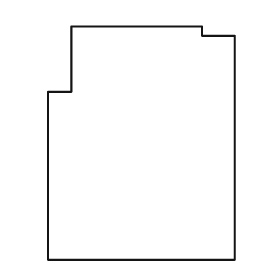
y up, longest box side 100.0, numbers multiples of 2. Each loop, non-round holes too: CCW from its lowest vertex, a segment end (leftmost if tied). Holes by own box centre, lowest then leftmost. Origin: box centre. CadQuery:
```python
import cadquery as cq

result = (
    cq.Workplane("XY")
    .moveTo(-40.0, -50.0)
    .lineTo(40.0, -50.0)
    .lineTo(40.0, 46.0)
    .lineTo(26.0, 46.0)
    .lineTo(26.0, 50.0)
    .lineTo(-30.0, 50.0)
    .lineTo(-30.0, 22.0)
    .lineTo(-40.0, 22.0)
    .close()
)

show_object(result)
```